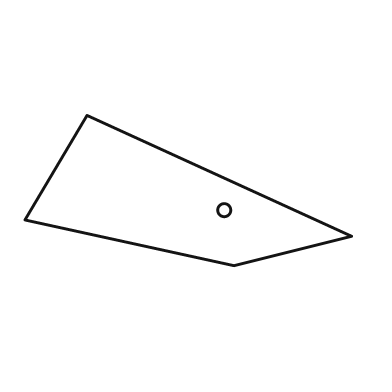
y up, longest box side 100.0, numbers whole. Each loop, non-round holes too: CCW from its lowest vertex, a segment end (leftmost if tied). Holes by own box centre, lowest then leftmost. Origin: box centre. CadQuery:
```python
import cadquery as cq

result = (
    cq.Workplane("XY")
    .moveTo(14.0, -23.0)
    .lineTo(50.0, -14.0)
    .lineTo(-31.0, 23.0)
    .lineTo(-50.0, -9.0)
    .close()
    .moveTo(11.0, -6.0)
    .circle(2.0)
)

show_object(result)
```